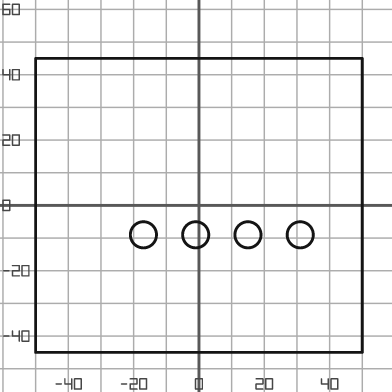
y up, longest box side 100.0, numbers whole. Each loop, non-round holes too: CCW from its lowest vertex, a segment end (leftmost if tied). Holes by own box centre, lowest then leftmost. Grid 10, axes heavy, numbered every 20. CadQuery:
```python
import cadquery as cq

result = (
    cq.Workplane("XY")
    .moveTo(-50.0, -45.0)
    .lineTo(50.0, -45.0)
    .lineTo(50.0, 45.0)
    .lineTo(-50.0, 45.0)
    .close()
    .moveTo(-17.0, -9.0)
    .circle(4.0)
    .moveTo(-1.0, -9.0)
    .circle(4.0)
    .moveTo(15.0, -9.0)
    .circle(4.0)
    .moveTo(31.0, -9.0)
    .circle(4.0)
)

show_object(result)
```